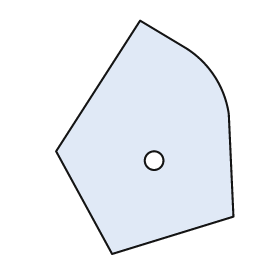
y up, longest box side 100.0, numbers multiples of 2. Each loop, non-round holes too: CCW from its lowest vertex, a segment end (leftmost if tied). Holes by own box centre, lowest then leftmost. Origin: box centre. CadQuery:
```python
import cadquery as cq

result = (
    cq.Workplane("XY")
    .moveTo(-14.0, -50.0)
    .lineTo(38.0, -34.0)
    .lineTo(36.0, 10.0)
    .threePointArc((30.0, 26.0), (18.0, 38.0))
    .lineTo(-2.0, 50.0)
    .lineTo(-38.0, -6.0)
    .close()
    .moveTo(4.0, -10.0)
    .circle(4.0)
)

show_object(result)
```